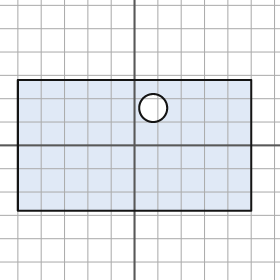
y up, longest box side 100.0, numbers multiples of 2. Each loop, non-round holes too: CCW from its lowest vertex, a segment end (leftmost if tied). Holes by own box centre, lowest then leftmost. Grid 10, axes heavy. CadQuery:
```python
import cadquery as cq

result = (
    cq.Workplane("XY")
    .moveTo(-50.0, -28.0)
    .lineTo(50.0, -28.0)
    .lineTo(50.0, 28.0)
    .lineTo(-50.0, 28.0)
    .close()
    .moveTo(8.0, 16.0)
    .circle(6.0)
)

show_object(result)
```